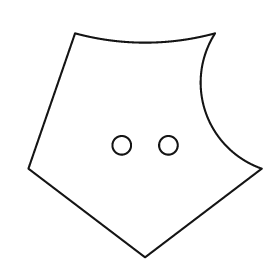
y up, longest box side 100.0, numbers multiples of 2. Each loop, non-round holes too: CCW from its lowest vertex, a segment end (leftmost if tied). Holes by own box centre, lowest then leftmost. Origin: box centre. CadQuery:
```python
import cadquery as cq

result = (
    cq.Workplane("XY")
    .moveTo(0.0, -48.0)
    .lineTo(50.0, -10.0)
    .threePointArc((26.0, 14.0), (30.0, 48.0))
    .threePointArc((0.0, 44.0), (-30.0, 48.0))
    .lineTo(-50.0, -10.0)
    .close()
    .moveTo(-10.0, 0.0)
    .circle(4.0)
    .moveTo(10.0, 0.0)
    .circle(4.0)
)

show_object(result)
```